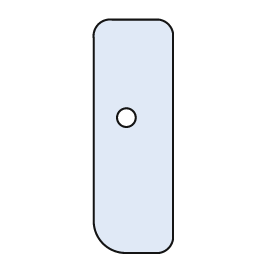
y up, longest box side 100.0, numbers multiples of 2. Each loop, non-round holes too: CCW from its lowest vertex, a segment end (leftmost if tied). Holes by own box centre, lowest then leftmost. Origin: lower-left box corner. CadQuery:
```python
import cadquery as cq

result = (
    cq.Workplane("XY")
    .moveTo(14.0, 0.0)
    .lineTo(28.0, 0.0)
    .threePointArc((32.0, 2.0), (34.0, 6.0))
    .lineTo(34.0, 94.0)
    .threePointArc((32.0, 98.0), (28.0, 100.0))
    .lineTo(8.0, 100.0)
    .threePointArc((2.0, 98.0), (0.0, 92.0))
    .lineTo(0.0, 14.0)
    .threePointArc((4.0, 4.0), (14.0, 0.0))
    .close()
    .moveTo(14.0, 58.0)
    .circle(4.0)
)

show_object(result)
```